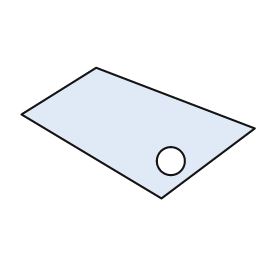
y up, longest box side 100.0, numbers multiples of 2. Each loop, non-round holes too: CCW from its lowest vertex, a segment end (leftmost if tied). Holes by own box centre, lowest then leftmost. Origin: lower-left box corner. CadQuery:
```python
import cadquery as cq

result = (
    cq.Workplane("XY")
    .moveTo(60.0, 0.0)
    .lineTo(100.0, 30.0)
    .lineTo(32.0, 56.0)
    .lineTo(0.0, 36.0)
    .close()
    .moveTo(64.0, 16.0)
    .circle(6.0)
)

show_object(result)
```